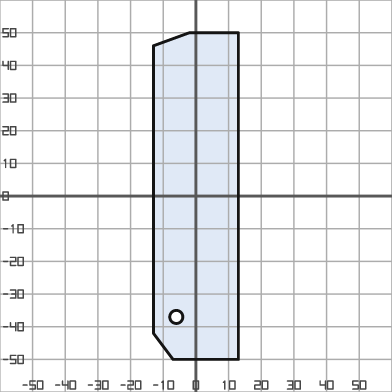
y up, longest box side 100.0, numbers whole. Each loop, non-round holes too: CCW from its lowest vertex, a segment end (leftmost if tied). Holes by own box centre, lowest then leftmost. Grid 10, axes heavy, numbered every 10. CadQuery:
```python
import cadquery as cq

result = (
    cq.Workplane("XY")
    .moveTo(-7.0, -50.0)
    .lineTo(13.0, -50.0)
    .lineTo(13.0, 50.0)
    .lineTo(-2.0, 50.0)
    .lineTo(-13.0, 46.0)
    .lineTo(-13.0, -42.0)
    .close()
    .moveTo(-6.0, -37.0)
    .circle(2.0)
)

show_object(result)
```